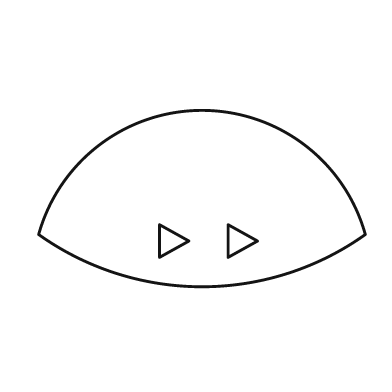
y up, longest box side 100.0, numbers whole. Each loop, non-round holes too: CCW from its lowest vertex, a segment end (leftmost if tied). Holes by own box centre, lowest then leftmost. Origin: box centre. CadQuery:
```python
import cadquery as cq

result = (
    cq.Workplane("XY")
    .moveTo(-50.0, -11.0)
    .threePointArc((0.0, -27.0), (50.0, -11.0))
    .threePointArc((0.0, 27.0), (-50.0, -11.0))
    .close()
    .moveTo(-13.0, -18.0)
    .lineTo(-4.0, -13.0)
    .lineTo(-13.0, -8.0)
    .close()
    .moveTo(8.0, -18.0)
    .lineTo(17.0, -13.0)
    .lineTo(8.0, -8.0)
    .close()
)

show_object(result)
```